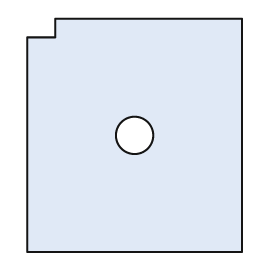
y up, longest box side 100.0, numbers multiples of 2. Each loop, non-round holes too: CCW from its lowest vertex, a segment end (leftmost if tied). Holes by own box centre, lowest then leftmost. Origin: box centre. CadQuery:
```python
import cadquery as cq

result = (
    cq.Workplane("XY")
    .moveTo(-46.0, -50.0)
    .lineTo(46.0, -50.0)
    .lineTo(46.0, 50.0)
    .lineTo(-34.0, 50.0)
    .lineTo(-34.0, 42.0)
    .lineTo(-46.0, 42.0)
    .close()
    .moveTo(0.0, 0.0)
    .circle(8.0)
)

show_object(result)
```